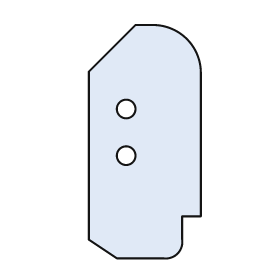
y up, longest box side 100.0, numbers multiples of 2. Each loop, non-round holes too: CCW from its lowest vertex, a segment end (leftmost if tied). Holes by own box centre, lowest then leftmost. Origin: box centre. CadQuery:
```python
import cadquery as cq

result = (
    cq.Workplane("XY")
    .moveTo(-12.0, -50.0)
    .lineTo(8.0, -50.0)
    .threePointArc((14.0, -48.0), (16.0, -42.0))
    .lineTo(16.0, -32.0)
    .lineTo(24.0, -32.0)
    .lineTo(24.0, 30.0)
    .threePointArc((18.0, 44.0), (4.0, 50.0))
    .lineTo(-4.0, 50.0)
    .lineTo(-24.0, 30.0)
    .lineTo(-24.0, -42.0)
    .close()
    .moveTo(-8.0, -6.0)
    .circle(4.0)
    .moveTo(-8.0, 14.0)
    .circle(4.0)
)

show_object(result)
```